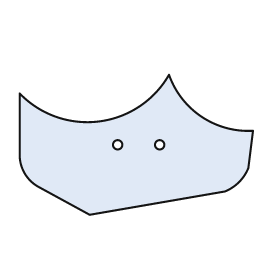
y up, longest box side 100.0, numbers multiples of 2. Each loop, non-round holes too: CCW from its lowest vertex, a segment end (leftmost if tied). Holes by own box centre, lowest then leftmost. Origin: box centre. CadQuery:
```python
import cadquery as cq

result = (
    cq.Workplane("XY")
    .moveTo(-20.0, -30.0)
    .lineTo(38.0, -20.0)
    .threePointArc((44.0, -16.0), (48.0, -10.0))
    .lineTo(50.0, 6.0)
    .threePointArc((28.0, 12.0), (14.0, 30.0))
    .threePointArc((-16.0, 10.0), (-50.0, 22.0))
    .lineTo(-50.0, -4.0)
    .threePointArc((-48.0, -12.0), (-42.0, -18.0))
    .close()
    .moveTo(-8.0, 0.0)
    .circle(2.0)
    .moveTo(10.0, 0.0)
    .circle(2.0)
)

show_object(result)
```